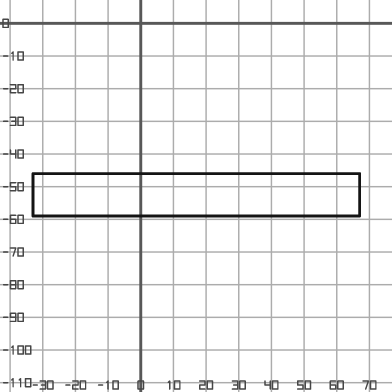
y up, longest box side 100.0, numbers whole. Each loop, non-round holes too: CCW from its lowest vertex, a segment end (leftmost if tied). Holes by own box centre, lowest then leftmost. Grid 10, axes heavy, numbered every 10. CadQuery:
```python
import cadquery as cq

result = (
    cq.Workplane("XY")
    .moveTo(-33.0, -59.0)
    .lineTo(67.0, -59.0)
    .lineTo(67.0, -46.0)
    .lineTo(-33.0, -46.0)
    .close()
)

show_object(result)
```